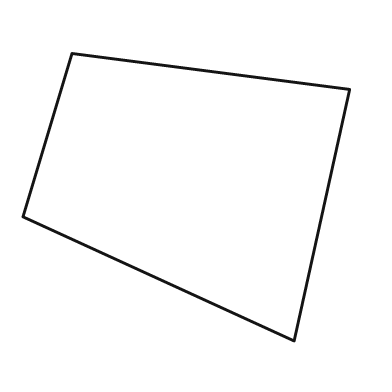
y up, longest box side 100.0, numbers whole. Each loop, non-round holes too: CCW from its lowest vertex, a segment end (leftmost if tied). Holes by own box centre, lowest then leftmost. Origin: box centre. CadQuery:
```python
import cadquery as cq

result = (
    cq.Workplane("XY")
    .moveTo(33.0, -44.0)
    .lineTo(50.0, 33.0)
    .lineTo(-35.0, 44.0)
    .lineTo(-50.0, -6.0)
    .close()
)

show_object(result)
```